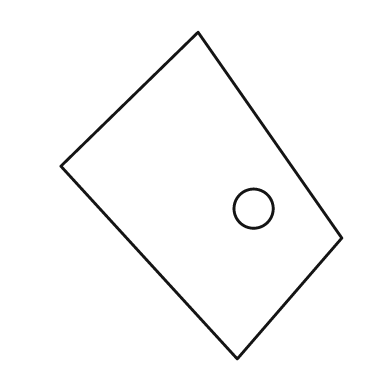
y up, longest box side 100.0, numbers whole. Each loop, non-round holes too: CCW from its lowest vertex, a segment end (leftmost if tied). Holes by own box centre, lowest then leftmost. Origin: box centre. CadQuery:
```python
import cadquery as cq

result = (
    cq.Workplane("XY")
    .moveTo(11.0, -50.0)
    .lineTo(43.0, -13.0)
    .lineTo(-1.0, 50.0)
    .lineTo(-43.0, 9.0)
    .close()
    .moveTo(16.0, -4.0)
    .circle(6.0)
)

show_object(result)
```